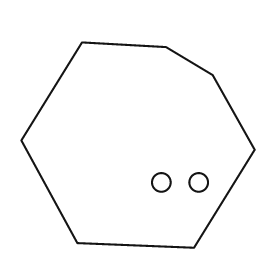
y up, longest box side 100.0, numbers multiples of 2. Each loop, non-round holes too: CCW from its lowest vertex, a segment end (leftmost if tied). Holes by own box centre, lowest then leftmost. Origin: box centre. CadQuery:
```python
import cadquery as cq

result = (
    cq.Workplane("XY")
    .moveTo(24.0, -44.0)
    .lineTo(50.0, -2.0)
    .lineTo(32.0, 30.0)
    .lineTo(12.0, 42.0)
    .lineTo(-24.0, 44.0)
    .lineTo(-50.0, 2.0)
    .lineTo(-26.0, -42.0)
    .close()
    .moveTo(10.0, -16.0)
    .circle(4.0)
    .moveTo(26.0, -16.0)
    .circle(4.0)
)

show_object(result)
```